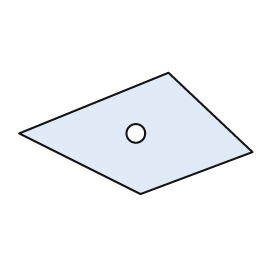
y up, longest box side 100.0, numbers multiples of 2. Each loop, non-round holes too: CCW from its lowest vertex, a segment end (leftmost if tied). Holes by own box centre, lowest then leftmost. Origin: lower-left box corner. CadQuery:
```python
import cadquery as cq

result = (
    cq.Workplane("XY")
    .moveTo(52.0, 0.0)
    .lineTo(100.0, 18.0)
    .lineTo(64.0, 52.0)
    .lineTo(0.0, 26.0)
    .close()
    .moveTo(50.0, 26.0)
    .circle(4.0)
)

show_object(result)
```